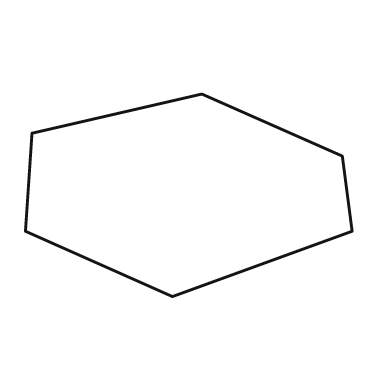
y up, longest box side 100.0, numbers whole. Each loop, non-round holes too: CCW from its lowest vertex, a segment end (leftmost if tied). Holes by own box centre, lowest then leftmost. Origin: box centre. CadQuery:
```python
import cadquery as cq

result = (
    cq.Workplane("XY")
    .moveTo(-5.0, -31.0)
    .lineTo(50.0, -11.0)
    .lineTo(47.0, 12.0)
    .lineTo(4.0, 31.0)
    .lineTo(-48.0, 19.0)
    .lineTo(-50.0, -11.0)
    .close()
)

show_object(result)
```